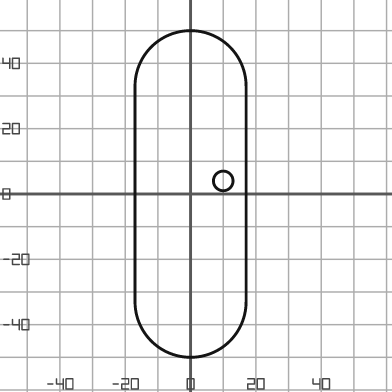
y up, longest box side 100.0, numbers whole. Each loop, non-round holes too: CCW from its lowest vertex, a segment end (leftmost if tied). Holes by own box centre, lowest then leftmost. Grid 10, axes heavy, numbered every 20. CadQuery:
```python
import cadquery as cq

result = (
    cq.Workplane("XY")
    .moveTo(-17.0, -33.0)
    .threePointArc((0.0, -50.0), (17.0, -33.0))
    .lineTo(17.0, 33.0)
    .threePointArc((0.0, 50.0), (-17.0, 33.0))
    .close()
    .moveTo(10.0, 4.0)
    .circle(3.0)
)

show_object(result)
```